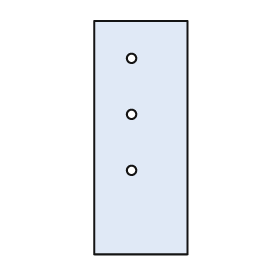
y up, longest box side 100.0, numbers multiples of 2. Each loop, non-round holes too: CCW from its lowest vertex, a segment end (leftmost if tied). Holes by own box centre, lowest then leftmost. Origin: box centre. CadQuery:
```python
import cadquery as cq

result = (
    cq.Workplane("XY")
    .moveTo(-20.0, -50.0)
    .lineTo(20.0, -50.0)
    .lineTo(20.0, 50.0)
    .lineTo(-20.0, 50.0)
    .close()
    .moveTo(-4.0, -14.0)
    .circle(2.0)
    .moveTo(-4.0, 10.0)
    .circle(2.0)
    .moveTo(-4.0, 34.0)
    .circle(2.0)
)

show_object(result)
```